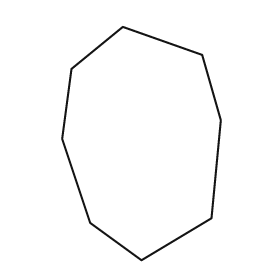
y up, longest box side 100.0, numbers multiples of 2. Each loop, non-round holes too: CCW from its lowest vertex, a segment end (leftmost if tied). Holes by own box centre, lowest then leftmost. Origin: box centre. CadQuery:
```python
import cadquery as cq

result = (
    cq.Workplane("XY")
    .moveTo(0.0, -50.0)
    .lineTo(30.0, -32.0)
    .lineTo(34.0, 10.0)
    .lineTo(26.0, 38.0)
    .lineTo(-8.0, 50.0)
    .lineTo(-30.0, 32.0)
    .lineTo(-34.0, 2.0)
    .lineTo(-22.0, -34.0)
    .close()
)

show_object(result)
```